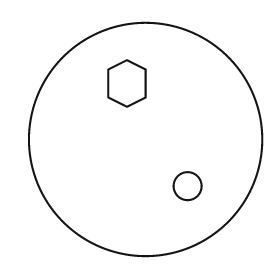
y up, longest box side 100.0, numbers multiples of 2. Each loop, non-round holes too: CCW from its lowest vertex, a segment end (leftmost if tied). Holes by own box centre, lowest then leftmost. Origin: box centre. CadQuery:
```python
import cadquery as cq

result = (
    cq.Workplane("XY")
    .moveTo(0.0, 0.0)
    .circle(50.0)
    .moveTo(18.0, -20.0)
    .circle(6.0)
    .moveTo(-8.0, 14.0)
    .lineTo(0.0, 18.0)
    .lineTo(0.0, 30.0)
    .lineTo(-8.0, 34.0)
    .lineTo(-16.0, 30.0)
    .lineTo(-16.0, 18.0)
    .close()
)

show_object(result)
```